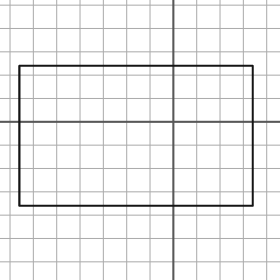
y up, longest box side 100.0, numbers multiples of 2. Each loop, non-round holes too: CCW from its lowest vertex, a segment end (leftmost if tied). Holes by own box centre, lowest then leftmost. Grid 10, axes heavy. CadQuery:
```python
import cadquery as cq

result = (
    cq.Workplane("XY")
    .moveTo(-66.0, -36.0)
    .lineTo(34.0, -36.0)
    .lineTo(34.0, 24.0)
    .lineTo(-66.0, 24.0)
    .close()
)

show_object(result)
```